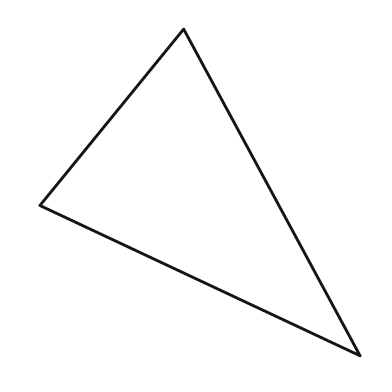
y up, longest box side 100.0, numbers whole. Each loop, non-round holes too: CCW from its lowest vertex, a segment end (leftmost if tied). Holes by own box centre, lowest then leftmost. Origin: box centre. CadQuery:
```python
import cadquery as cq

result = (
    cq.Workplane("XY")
    .moveTo(49.0, -50.0)
    .lineTo(-5.0, 50.0)
    .lineTo(-49.0, -4.0)
    .close()
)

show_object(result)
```